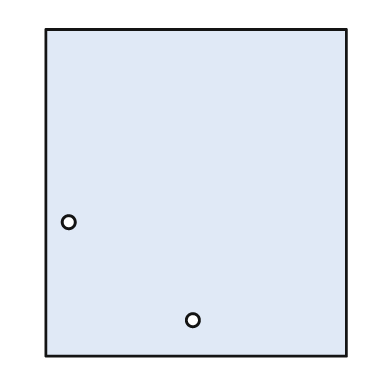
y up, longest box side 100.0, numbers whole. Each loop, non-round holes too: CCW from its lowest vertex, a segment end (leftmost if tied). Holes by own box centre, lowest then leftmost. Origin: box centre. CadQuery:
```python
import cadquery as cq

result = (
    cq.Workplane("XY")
    .moveTo(-46.0, -50.0)
    .lineTo(46.0, -50.0)
    .lineTo(46.0, 50.0)
    .lineTo(-46.0, 50.0)
    .close()
    .moveTo(-1.0, -39.0)
    .circle(2.0)
    .moveTo(-39.0, -9.0)
    .circle(2.0)
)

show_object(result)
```